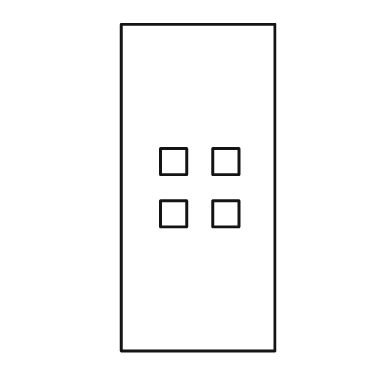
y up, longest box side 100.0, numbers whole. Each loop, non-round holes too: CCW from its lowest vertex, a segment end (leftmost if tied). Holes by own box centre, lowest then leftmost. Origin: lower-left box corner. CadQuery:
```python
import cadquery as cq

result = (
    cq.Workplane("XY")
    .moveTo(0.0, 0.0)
    .lineTo(47.0, 0.0)
    .lineTo(47.0, 100.0)
    .lineTo(0.0, 100.0)
    .close()
    .moveTo(12.0, 38.0)
    .lineTo(20.0, 38.0)
    .lineTo(20.0, 46.0)
    .lineTo(12.0, 46.0)
    .close()
    .moveTo(28.0, 38.0)
    .lineTo(36.0, 38.0)
    .lineTo(36.0, 46.0)
    .lineTo(28.0, 46.0)
    .close()
    .moveTo(12.0, 54.0)
    .lineTo(20.0, 54.0)
    .lineTo(20.0, 62.0)
    .lineTo(12.0, 62.0)
    .close()
    .moveTo(28.0, 54.0)
    .lineTo(36.0, 54.0)
    .lineTo(36.0, 62.0)
    .lineTo(28.0, 62.0)
    .close()
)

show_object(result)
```